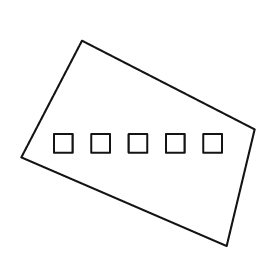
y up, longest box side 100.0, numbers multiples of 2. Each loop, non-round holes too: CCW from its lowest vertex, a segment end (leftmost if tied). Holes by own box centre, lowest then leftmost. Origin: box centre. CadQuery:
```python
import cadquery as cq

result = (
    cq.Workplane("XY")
    .moveTo(38.0, -44.0)
    .lineTo(50.0, 6.0)
    .lineTo(-24.0, 44.0)
    .lineTo(-50.0, -6.0)
    .close()
    .moveTo(-36.0, -4.0)
    .lineTo(-28.0, -4.0)
    .lineTo(-28.0, 4.0)
    .lineTo(-36.0, 4.0)
    .close()
    .moveTo(-20.0, -4.0)
    .lineTo(-12.0, -4.0)
    .lineTo(-12.0, 4.0)
    .lineTo(-20.0, 4.0)
    .close()
    .moveTo(-4.0, -4.0)
    .lineTo(4.0, -4.0)
    .lineTo(4.0, 4.0)
    .lineTo(-4.0, 4.0)
    .close()
    .moveTo(12.0, -4.0)
    .lineTo(20.0, -4.0)
    .lineTo(20.0, 4.0)
    .lineTo(12.0, 4.0)
    .close()
    .moveTo(28.0, -4.0)
    .lineTo(36.0, -4.0)
    .lineTo(36.0, 4.0)
    .lineTo(28.0, 4.0)
    .close()
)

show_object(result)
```